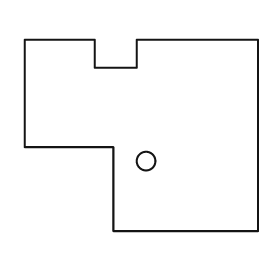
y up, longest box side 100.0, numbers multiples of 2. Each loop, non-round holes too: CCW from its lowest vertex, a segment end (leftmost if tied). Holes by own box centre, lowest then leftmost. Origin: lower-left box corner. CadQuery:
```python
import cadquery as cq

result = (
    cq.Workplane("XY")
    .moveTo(38.0, 0.0)
    .lineTo(100.0, 0.0)
    .lineTo(100.0, 82.0)
    .lineTo(48.0, 82.0)
    .lineTo(48.0, 70.0)
    .lineTo(30.0, 70.0)
    .lineTo(30.0, 82.0)
    .lineTo(0.0, 82.0)
    .lineTo(0.0, 36.0)
    .lineTo(38.0, 36.0)
    .close()
    .moveTo(52.0, 30.0)
    .circle(4.0)
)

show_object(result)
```